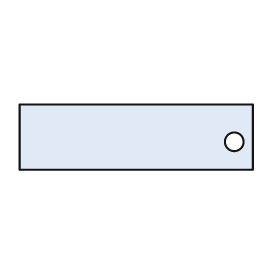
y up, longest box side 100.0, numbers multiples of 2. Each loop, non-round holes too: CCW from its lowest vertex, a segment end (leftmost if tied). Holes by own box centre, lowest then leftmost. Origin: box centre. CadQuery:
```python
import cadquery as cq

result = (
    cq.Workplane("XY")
    .moveTo(-50.0, -14.0)
    .lineTo(50.0, -14.0)
    .lineTo(50.0, 14.0)
    .lineTo(-50.0, 14.0)
    .close()
    .moveTo(42.0, -2.0)
    .circle(4.0)
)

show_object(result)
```